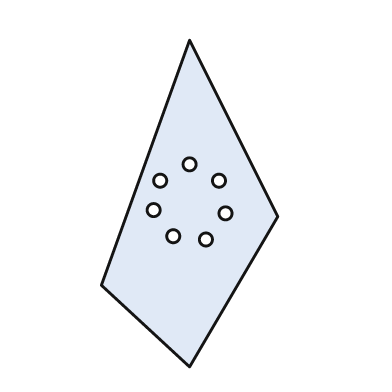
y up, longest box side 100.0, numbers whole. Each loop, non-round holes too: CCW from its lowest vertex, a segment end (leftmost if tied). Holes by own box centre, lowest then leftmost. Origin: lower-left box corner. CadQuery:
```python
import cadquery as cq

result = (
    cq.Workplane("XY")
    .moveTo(27.0, 0.0)
    .lineTo(54.0, 46.0)
    .lineTo(27.0, 100.0)
    .lineTo(0.0, 25.0)
    .close()
    .moveTo(32.0, 39.0)
    .circle(2.0)
    .moveTo(22.0, 40.0)
    .circle(2.0)
    .moveTo(38.0, 47.0)
    .circle(2.0)
    .moveTo(16.0, 48.0)
    .circle(2.0)
    .moveTo(18.0, 57.0)
    .circle(2.0)
    .moveTo(36.0, 57.0)
    .circle(2.0)
    .moveTo(27.0, 62.0)
    .circle(2.0)
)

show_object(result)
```